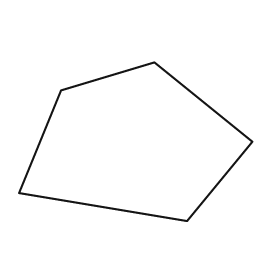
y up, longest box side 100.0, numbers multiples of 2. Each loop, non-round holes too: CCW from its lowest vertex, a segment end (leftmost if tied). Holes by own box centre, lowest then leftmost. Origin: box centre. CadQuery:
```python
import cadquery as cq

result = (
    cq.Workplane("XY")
    .moveTo(22.0, -34.0)
    .lineTo(50.0, 0.0)
    .lineTo(8.0, 34.0)
    .lineTo(-32.0, 22.0)
    .lineTo(-50.0, -22.0)
    .close()
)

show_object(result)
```